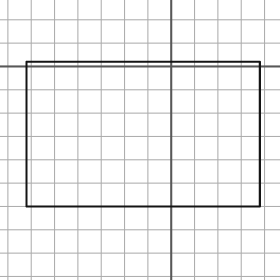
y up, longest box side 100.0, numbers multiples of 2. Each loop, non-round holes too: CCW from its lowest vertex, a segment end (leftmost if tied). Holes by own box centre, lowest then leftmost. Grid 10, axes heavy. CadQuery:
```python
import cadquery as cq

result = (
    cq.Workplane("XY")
    .moveTo(-62.0, -60.0)
    .lineTo(38.0, -60.0)
    .lineTo(38.0, 2.0)
    .lineTo(-62.0, 2.0)
    .close()
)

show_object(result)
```